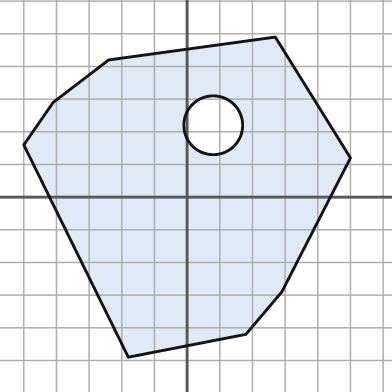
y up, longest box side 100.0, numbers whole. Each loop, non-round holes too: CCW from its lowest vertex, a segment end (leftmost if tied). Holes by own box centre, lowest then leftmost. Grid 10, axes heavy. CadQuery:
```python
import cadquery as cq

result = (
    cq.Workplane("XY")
    .moveTo(-18.0, -49.0)
    .lineTo(18.0, -42.0)
    .lineTo(29.0, -29.0)
    .lineTo(50.0, 12.0)
    .lineTo(27.0, 49.0)
    .lineTo(-24.0, 42.0)
    .lineTo(-41.0, 29.0)
    .lineTo(-50.0, 16.0)
    .close()
    .moveTo(8.0, 22.0)
    .circle(9.0)
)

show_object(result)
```